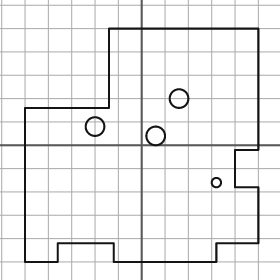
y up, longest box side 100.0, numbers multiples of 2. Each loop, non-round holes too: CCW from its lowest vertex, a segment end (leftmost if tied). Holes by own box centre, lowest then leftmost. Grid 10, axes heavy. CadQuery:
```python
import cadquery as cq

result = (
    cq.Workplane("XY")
    .moveTo(-50.0, -50.0)
    .lineTo(-36.0, -50.0)
    .lineTo(-36.0, -42.0)
    .lineTo(-12.0, -42.0)
    .lineTo(-12.0, -50.0)
    .lineTo(32.0, -50.0)
    .lineTo(32.0, -42.0)
    .lineTo(50.0, -42.0)
    .lineTo(50.0, -18.0)
    .lineTo(40.0, -18.0)
    .lineTo(40.0, -2.0)
    .lineTo(50.0, -2.0)
    .lineTo(50.0, 50.0)
    .lineTo(-14.0, 50.0)
    .lineTo(-14.0, 16.0)
    .lineTo(-50.0, 16.0)
    .close()
    .moveTo(32.0, -16.0)
    .circle(2.0)
    .moveTo(6.0, 4.0)
    .circle(4.0)
    .moveTo(-20.0, 8.0)
    .circle(4.0)
    .moveTo(16.0, 20.0)
    .circle(4.0)
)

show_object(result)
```